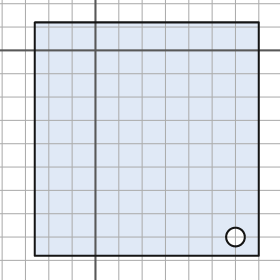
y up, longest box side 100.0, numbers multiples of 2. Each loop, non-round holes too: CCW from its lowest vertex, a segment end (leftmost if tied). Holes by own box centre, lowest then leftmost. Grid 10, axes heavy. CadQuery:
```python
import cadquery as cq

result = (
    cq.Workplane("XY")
    .moveTo(-26.0, -88.0)
    .lineTo(70.0, -88.0)
    .lineTo(70.0, 12.0)
    .lineTo(-26.0, 12.0)
    .close()
    .moveTo(60.0, -80.0)
    .circle(4.0)
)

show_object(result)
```